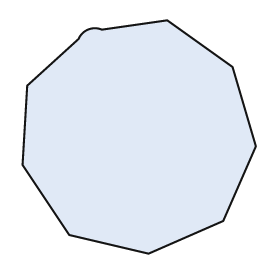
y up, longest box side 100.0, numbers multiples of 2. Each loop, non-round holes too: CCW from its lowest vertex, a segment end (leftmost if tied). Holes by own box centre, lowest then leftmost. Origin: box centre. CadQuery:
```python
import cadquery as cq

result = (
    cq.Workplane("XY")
    .moveTo(4.0, -50.0)
    .lineTo(36.0, -36.0)
    .lineTo(50.0, -4.0)
    .lineTo(40.0, 30.0)
    .lineTo(12.0, 50.0)
    .lineTo(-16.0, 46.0)
    .threePointArc((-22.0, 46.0), (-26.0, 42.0))
    .lineTo(-48.0, 22.0)
    .lineTo(-50.0, -12.0)
    .lineTo(-30.0, -42.0)
    .close()
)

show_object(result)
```